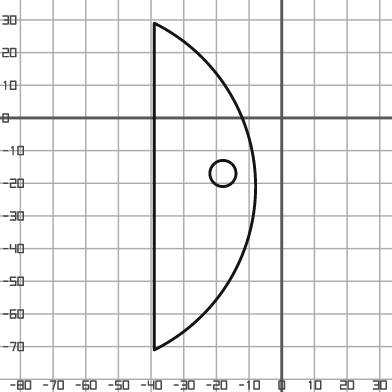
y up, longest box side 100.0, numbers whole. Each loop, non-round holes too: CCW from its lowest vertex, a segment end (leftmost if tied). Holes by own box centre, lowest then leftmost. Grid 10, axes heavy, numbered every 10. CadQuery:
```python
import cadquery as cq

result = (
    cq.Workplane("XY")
    .moveTo(-39.0, -71.0)
    .threePointArc((-8.0, -21.0), (-39.0, 29.0))
    .close()
    .moveTo(-18.0, -17.0)
    .circle(4.0)
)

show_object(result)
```